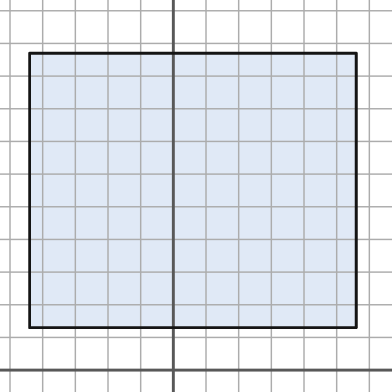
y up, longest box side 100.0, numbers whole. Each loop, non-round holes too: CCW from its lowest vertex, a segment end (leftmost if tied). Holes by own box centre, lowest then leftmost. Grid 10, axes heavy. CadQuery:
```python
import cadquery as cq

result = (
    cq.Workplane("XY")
    .moveTo(-44.0, 13.0)
    .lineTo(56.0, 13.0)
    .lineTo(56.0, 97.0)
    .lineTo(-44.0, 97.0)
    .close()
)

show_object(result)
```